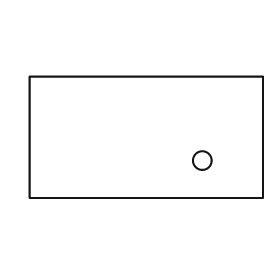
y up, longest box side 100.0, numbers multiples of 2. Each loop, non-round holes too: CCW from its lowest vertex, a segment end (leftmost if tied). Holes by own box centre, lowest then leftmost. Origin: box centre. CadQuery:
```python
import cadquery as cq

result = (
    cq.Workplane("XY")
    .moveTo(-50.0, -26.0)
    .lineTo(50.0, -26.0)
    .lineTo(50.0, 26.0)
    .lineTo(-50.0, 26.0)
    .close()
    .moveTo(24.0, -10.0)
    .circle(4.0)
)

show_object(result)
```